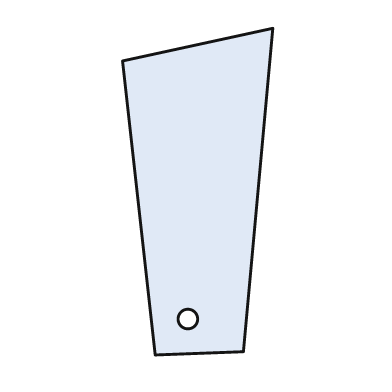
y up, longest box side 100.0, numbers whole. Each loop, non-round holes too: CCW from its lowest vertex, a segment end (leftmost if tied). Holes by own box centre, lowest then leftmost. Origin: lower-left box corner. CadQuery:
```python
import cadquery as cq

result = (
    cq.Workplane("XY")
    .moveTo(10.0, 0.0)
    .lineTo(37.0, 1.0)
    .lineTo(46.0, 100.0)
    .lineTo(0.0, 90.0)
    .close()
    .moveTo(20.0, 11.0)
    .circle(3.0)
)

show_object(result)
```